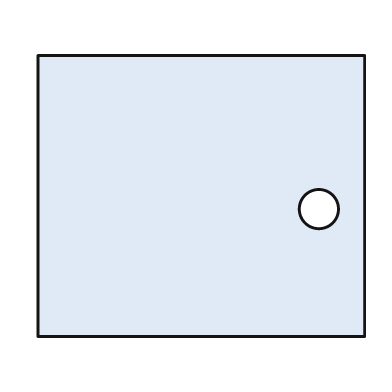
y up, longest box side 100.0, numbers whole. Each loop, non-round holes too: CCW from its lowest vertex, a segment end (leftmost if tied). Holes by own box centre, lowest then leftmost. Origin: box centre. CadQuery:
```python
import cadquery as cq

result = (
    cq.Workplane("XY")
    .moveTo(-50.0, -43.0)
    .lineTo(50.0, -43.0)
    .lineTo(50.0, 43.0)
    .lineTo(-50.0, 43.0)
    .close()
    .moveTo(36.0, -4.0)
    .circle(6.0)
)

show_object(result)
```